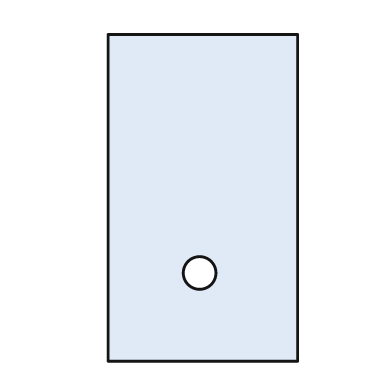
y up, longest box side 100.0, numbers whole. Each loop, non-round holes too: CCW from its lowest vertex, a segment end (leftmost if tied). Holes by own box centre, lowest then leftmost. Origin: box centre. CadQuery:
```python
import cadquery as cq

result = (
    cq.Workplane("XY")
    .moveTo(-29.0, -50.0)
    .lineTo(29.0, -50.0)
    .lineTo(29.0, 50.0)
    .lineTo(-29.0, 50.0)
    .close()
    .moveTo(-1.0, -23.0)
    .circle(5.0)
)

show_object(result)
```